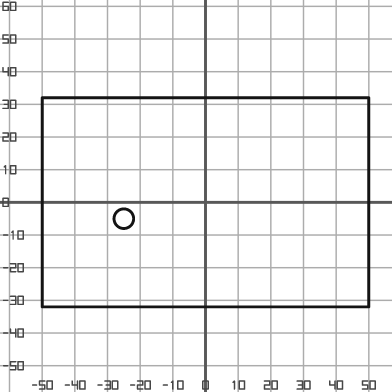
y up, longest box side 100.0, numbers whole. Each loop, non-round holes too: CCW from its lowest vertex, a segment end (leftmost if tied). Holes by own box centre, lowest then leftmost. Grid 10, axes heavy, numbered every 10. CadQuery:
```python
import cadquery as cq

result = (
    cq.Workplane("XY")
    .moveTo(-50.0, -32.0)
    .lineTo(50.0, -32.0)
    .lineTo(50.0, 32.0)
    .lineTo(-50.0, 32.0)
    .close()
    .moveTo(-25.0, -5.0)
    .circle(3.0)
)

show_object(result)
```